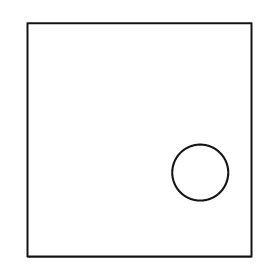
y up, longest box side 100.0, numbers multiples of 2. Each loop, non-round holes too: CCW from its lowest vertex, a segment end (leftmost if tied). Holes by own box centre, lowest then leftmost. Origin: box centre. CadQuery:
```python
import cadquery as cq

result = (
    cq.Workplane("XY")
    .moveTo(-48.0, -50.0)
    .lineTo(48.0, -50.0)
    .lineTo(48.0, 50.0)
    .lineTo(-48.0, 50.0)
    .close()
    .moveTo(26.0, -14.0)
    .circle(12.0)
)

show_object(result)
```